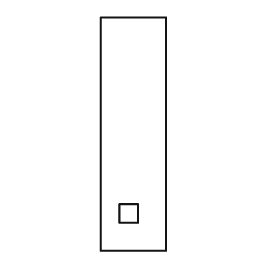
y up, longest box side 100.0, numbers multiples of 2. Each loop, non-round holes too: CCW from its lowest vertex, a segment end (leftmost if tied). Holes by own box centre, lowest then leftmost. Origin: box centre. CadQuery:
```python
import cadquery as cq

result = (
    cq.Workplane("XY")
    .moveTo(-14.0, -50.0)
    .lineTo(14.0, -50.0)
    .lineTo(14.0, 50.0)
    .lineTo(-14.0, 50.0)
    .close()
    .moveTo(-6.0, -38.0)
    .lineTo(2.0, -38.0)
    .lineTo(2.0, -30.0)
    .lineTo(-6.0, -30.0)
    .close()
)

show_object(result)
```